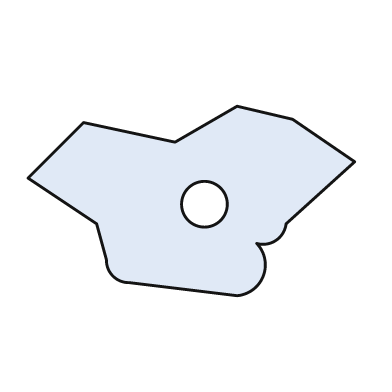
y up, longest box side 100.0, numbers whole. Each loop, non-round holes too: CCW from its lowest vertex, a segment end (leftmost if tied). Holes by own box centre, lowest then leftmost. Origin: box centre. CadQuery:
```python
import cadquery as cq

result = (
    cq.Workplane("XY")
    .moveTo(14.0, -29.0)
    .threePointArc((22.0, -23.0), (20.0, -13.0))
    .threePointArc((26.0, -12.0), (29.0, -7.0))
    .lineTo(50.0, 12.0)
    .lineTo(31.0, 25.0)
    .lineTo(14.0, 29.0)
    .lineTo(-5.0, 18.0)
    .lineTo(-33.0, 24.0)
    .lineTo(-50.0, 7.0)
    .lineTo(-29.0, -7.0)
    .lineTo(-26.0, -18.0)
    .threePointArc((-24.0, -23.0), (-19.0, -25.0))
    .close()
    .moveTo(4.0, -1.0)
    .circle(7.0)
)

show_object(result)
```